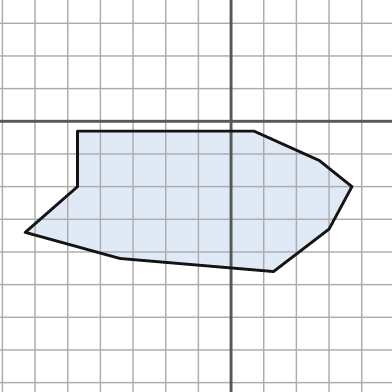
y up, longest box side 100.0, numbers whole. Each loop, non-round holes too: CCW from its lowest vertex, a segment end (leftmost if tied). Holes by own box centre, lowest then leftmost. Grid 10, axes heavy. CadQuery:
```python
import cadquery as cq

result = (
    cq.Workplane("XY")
    .moveTo(13.0, -46.0)
    .lineTo(30.0, -33.0)
    .lineTo(37.0, -20.0)
    .lineTo(27.0, -12.0)
    .lineTo(7.0, -3.0)
    .lineTo(-47.0, -3.0)
    .lineTo(-47.0, -20.0)
    .lineTo(-63.0, -34.0)
    .lineTo(-34.0, -42.0)
    .close()
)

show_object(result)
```